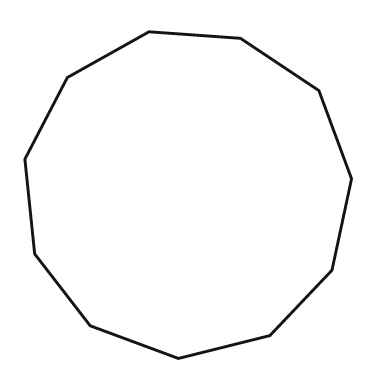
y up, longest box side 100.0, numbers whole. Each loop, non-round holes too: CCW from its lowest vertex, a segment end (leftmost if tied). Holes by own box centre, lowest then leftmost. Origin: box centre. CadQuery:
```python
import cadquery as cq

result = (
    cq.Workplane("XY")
    .moveTo(-3.0, -50.0)
    .lineTo(25.0, -43.0)
    .lineTo(44.0, -23.0)
    .lineTo(50.0, 5.0)
    .lineTo(40.0, 32.0)
    .lineTo(16.0, 48.0)
    .lineTo(-12.0, 50.0)
    .lineTo(-37.0, 36.0)
    .lineTo(-50.0, 11.0)
    .lineTo(-47.0, -18.0)
    .lineTo(-30.0, -40.0)
    .close()
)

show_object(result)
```